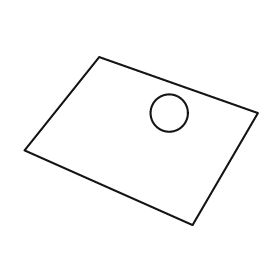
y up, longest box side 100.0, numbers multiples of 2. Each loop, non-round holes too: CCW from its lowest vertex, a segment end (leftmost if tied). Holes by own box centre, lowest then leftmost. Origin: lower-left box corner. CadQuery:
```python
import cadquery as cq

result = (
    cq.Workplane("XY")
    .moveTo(72.0, 0.0)
    .lineTo(100.0, 48.0)
    .lineTo(32.0, 72.0)
    .lineTo(0.0, 32.0)
    .close()
    .moveTo(62.0, 48.0)
    .circle(8.0)
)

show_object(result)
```